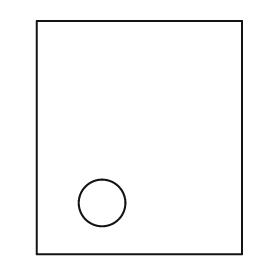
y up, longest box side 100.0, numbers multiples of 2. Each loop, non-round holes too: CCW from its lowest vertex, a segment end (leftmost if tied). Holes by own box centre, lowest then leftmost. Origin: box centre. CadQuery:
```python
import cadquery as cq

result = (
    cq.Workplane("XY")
    .moveTo(-44.0, -50.0)
    .lineTo(44.0, -50.0)
    .lineTo(44.0, 50.0)
    .lineTo(-44.0, 50.0)
    .close()
    .moveTo(-16.0, -28.0)
    .circle(10.0)
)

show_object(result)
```